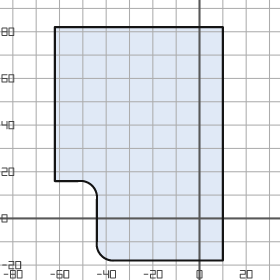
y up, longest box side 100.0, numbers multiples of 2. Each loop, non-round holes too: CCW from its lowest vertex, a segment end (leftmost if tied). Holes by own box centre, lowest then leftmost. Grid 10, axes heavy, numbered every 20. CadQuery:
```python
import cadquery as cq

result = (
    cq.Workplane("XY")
    .moveTo(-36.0, -18.0)
    .lineTo(10.0, -18.0)
    .lineTo(10.0, 82.0)
    .lineTo(-62.0, 82.0)
    .lineTo(-62.0, 16.0)
    .lineTo(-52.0, 16.0)
    .threePointArc((-46.0, 14.0), (-44.0, 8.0))
    .lineTo(-44.0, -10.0)
    .threePointArc((-42.0, -16.0), (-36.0, -18.0))
    .close()
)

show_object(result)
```